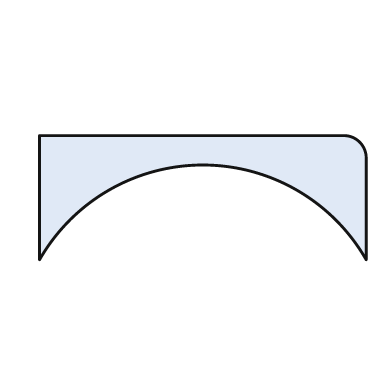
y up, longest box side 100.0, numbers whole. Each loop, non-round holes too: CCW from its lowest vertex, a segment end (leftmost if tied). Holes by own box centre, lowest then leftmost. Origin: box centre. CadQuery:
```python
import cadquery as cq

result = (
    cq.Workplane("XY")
    .moveTo(-50.0, -19.0)
    .threePointArc((0.0, 10.0), (50.0, -19.0))
    .lineTo(50.0, 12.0)
    .threePointArc((48.0, 17.0), (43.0, 19.0))
    .lineTo(-50.0, 19.0)
    .close()
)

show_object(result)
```